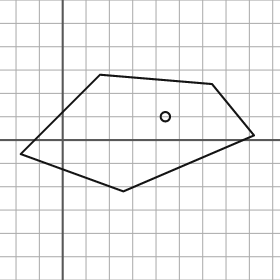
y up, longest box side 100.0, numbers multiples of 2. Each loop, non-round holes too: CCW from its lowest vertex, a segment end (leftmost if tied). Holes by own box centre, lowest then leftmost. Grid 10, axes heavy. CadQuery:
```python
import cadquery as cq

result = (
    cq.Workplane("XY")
    .moveTo(26.0, -22.0)
    .lineTo(82.0, 2.0)
    .lineTo(64.0, 24.0)
    .lineTo(16.0, 28.0)
    .lineTo(-18.0, -6.0)
    .close()
    .moveTo(44.0, 10.0)
    .circle(2.0)
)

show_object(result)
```